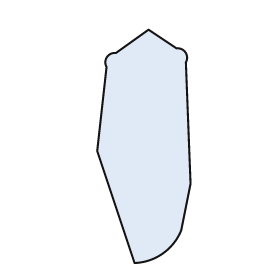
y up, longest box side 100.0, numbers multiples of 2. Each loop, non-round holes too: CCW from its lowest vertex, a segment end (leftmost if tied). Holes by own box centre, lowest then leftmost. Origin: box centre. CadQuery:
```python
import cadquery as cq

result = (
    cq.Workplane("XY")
    .moveTo(-4.0, -50.0)
    .threePointArc((8.0, -46.0), (16.0, -36.0))
    .lineTo(20.0, -16.0)
    .lineTo(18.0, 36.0)
    .threePointArc((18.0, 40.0), (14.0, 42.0))
    .lineTo(2.0, 50.0)
    .lineTo(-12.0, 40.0)
    .threePointArc((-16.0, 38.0), (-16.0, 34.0))
    .lineTo(-20.0, -2.0)
    .close()
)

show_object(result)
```